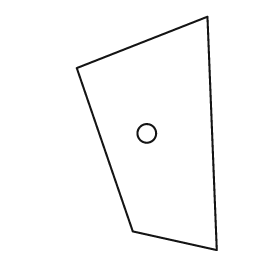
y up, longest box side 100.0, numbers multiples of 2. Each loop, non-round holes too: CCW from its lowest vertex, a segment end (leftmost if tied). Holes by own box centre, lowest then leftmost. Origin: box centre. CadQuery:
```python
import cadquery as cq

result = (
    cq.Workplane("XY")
    .moveTo(30.0, -50.0)
    .lineTo(26.0, 50.0)
    .lineTo(-30.0, 28.0)
    .lineTo(-6.0, -42.0)
    .close()
    .moveTo(0.0, 0.0)
    .circle(4.0)
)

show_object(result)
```